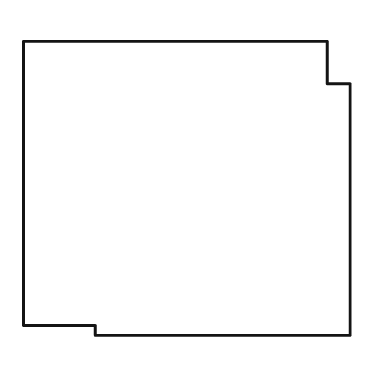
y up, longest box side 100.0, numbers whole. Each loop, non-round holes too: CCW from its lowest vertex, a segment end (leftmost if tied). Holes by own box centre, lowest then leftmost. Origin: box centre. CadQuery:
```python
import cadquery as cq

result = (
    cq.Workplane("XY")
    .moveTo(-28.0, -45.0)
    .lineTo(50.0, -45.0)
    .lineTo(50.0, 32.0)
    .lineTo(43.0, 32.0)
    .lineTo(43.0, 45.0)
    .lineTo(-50.0, 45.0)
    .lineTo(-50.0, -42.0)
    .lineTo(-28.0, -42.0)
    .close()
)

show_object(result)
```